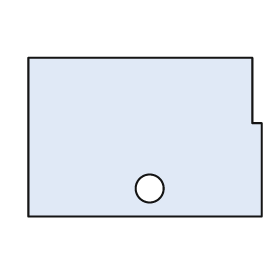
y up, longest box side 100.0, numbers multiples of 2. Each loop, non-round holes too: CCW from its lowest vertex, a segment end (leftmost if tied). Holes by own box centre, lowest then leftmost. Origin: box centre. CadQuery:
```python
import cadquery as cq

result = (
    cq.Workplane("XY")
    .moveTo(-50.0, -34.0)
    .lineTo(50.0, -34.0)
    .lineTo(50.0, 6.0)
    .lineTo(46.0, 6.0)
    .lineTo(46.0, 34.0)
    .lineTo(-50.0, 34.0)
    .close()
    .moveTo(2.0, -22.0)
    .circle(6.0)
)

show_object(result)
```